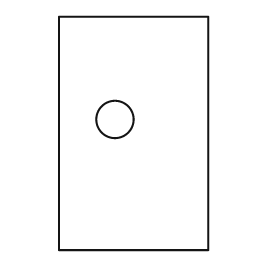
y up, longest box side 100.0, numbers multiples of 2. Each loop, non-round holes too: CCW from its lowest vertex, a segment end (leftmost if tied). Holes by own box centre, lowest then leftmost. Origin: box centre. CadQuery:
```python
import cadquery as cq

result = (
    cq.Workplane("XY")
    .moveTo(-32.0, -50.0)
    .lineTo(32.0, -50.0)
    .lineTo(32.0, 50.0)
    .lineTo(-32.0, 50.0)
    .close()
    .moveTo(-8.0, 6.0)
    .circle(8.0)
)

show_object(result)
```